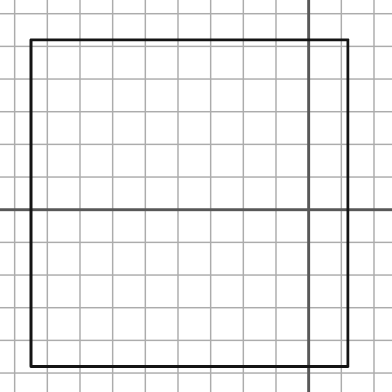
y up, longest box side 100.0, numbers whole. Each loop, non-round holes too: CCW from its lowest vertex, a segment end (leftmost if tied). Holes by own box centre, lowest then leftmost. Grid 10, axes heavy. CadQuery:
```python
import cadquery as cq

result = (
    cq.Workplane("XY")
    .moveTo(-85.0, -48.0)
    .lineTo(12.0, -48.0)
    .lineTo(12.0, 52.0)
    .lineTo(-85.0, 52.0)
    .close()
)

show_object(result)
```